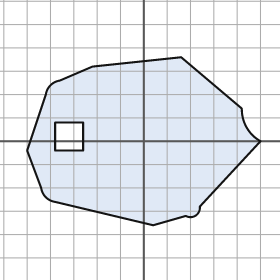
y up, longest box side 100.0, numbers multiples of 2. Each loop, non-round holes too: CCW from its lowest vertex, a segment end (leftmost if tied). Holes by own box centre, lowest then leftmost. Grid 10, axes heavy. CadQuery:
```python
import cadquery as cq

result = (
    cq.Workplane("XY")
    .moveTo(4.0, -36.0)
    .lineTo(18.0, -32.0)
    .threePointArc((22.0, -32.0), (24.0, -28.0))
    .lineTo(50.0, 0.0)
    .threePointArc((44.0, 6.0), (42.0, 14.0))
    .lineTo(16.0, 36.0)
    .lineTo(-22.0, 32.0)
    .lineTo(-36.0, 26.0)
    .threePointArc((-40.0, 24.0), (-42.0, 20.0))
    .lineTo(-50.0, -4.0)
    .lineTo(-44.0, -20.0)
    .threePointArc((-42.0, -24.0), (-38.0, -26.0))
    .close()
    .moveTo(-38.0, -4.0)
    .lineTo(-26.0, -4.0)
    .lineTo(-26.0, 8.0)
    .lineTo(-38.0, 8.0)
    .close()
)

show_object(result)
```